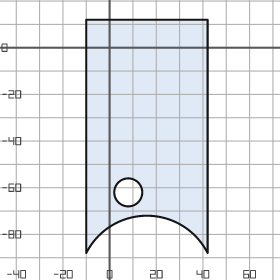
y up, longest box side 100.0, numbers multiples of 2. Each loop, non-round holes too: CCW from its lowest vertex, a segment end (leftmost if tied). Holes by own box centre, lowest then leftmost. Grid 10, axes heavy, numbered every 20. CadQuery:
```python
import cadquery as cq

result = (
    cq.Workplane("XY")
    .moveTo(-10.0, -88.0)
    .threePointArc((16.0, -72.0), (42.0, -88.0))
    .lineTo(42.0, 12.0)
    .lineTo(-10.0, 12.0)
    .close()
    .moveTo(8.0, -62.0)
    .circle(6.0)
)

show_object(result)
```